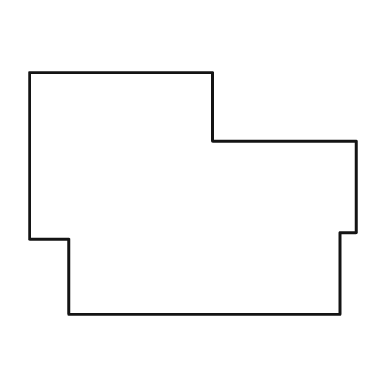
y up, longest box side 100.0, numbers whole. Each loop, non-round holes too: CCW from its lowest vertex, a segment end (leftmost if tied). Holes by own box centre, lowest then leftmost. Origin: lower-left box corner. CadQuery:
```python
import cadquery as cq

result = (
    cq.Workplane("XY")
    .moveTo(12.0, 0.0)
    .lineTo(95.0, 0.0)
    .lineTo(95.0, 25.0)
    .lineTo(100.0, 25.0)
    .lineTo(100.0, 53.0)
    .lineTo(56.0, 53.0)
    .lineTo(56.0, 74.0)
    .lineTo(0.0, 74.0)
    .lineTo(0.0, 23.0)
    .lineTo(12.0, 23.0)
    .close()
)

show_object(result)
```